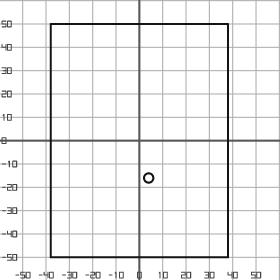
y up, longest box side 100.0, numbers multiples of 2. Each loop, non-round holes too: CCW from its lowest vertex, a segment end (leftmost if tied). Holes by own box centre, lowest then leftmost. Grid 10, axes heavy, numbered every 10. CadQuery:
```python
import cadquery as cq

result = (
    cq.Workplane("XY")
    .moveTo(-38.0, -50.0)
    .lineTo(38.0, -50.0)
    .lineTo(38.0, 50.0)
    .lineTo(-38.0, 50.0)
    .close()
    .moveTo(4.0, -16.0)
    .circle(2.0)
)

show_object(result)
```